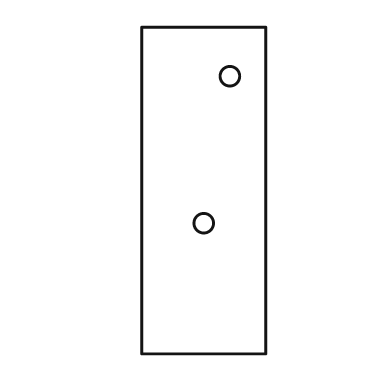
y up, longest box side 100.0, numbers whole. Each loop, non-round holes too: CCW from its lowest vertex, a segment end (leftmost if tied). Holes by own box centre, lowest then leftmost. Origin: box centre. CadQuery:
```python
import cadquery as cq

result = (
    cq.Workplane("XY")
    .moveTo(-19.0, -50.0)
    .lineTo(19.0, -50.0)
    .lineTo(19.0, 50.0)
    .lineTo(-19.0, 50.0)
    .close()
    .moveTo(0.0, -10.0)
    .circle(3.0)
    .moveTo(8.0, 35.0)
    .circle(3.0)
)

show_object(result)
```